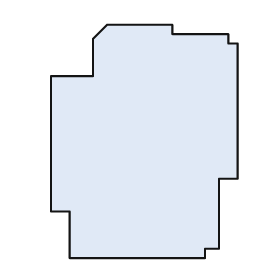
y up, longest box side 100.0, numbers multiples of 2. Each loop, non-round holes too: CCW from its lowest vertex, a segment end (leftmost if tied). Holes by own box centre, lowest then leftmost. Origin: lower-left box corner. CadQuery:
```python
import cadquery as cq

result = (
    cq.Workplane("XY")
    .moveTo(8.0, 0.0)
    .lineTo(66.0, 0.0)
    .lineTo(66.0, 4.0)
    .lineTo(72.0, 4.0)
    .lineTo(72.0, 34.0)
    .lineTo(80.0, 34.0)
    .lineTo(80.0, 92.0)
    .lineTo(76.0, 92.0)
    .lineTo(76.0, 96.0)
    .lineTo(52.0, 96.0)
    .lineTo(52.0, 100.0)
    .lineTo(24.0, 100.0)
    .lineTo(18.0, 94.0)
    .lineTo(18.0, 78.0)
    .lineTo(0.0, 78.0)
    .lineTo(0.0, 20.0)
    .lineTo(8.0, 20.0)
    .close()
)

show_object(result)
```